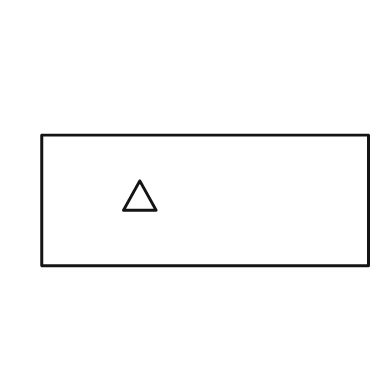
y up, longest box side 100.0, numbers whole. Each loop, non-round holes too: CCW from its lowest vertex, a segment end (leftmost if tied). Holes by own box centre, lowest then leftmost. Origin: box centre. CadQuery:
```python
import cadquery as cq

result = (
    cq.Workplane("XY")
    .moveTo(-50.0, -20.0)
    .lineTo(50.0, -20.0)
    .lineTo(50.0, 20.0)
    .lineTo(-50.0, 20.0)
    .close()
    .moveTo(-25.0, -3.0)
    .lineTo(-15.0, -3.0)
    .lineTo(-20.0, 6.0)
    .close()
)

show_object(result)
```